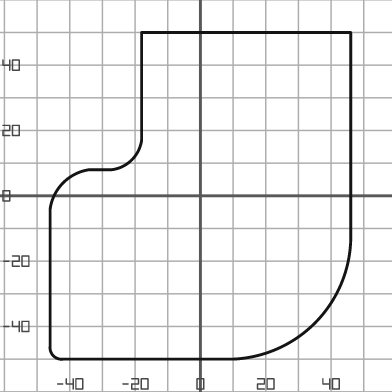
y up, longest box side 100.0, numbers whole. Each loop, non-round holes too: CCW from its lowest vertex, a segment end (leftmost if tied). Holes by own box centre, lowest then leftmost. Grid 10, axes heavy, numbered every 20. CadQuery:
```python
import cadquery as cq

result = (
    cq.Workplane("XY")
    .moveTo(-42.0, -50.0)
    .lineTo(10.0, -50.0)
    .threePointArc((35.0, -39.0), (46.0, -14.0))
    .lineTo(46.0, 50.0)
    .lineTo(-18.0, 50.0)
    .lineTo(-18.0, 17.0)
    .threePointArc((-21.0, 11.0), (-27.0, 8.0))
    .lineTo(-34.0, 8.0)
    .threePointArc((-42.0, 4.0), (-46.0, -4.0))
    .lineTo(-46.0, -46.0)
    .threePointArc((-45.0, -49.0), (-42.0, -50.0))
    .close()
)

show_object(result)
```